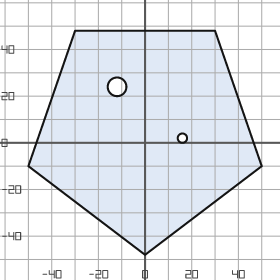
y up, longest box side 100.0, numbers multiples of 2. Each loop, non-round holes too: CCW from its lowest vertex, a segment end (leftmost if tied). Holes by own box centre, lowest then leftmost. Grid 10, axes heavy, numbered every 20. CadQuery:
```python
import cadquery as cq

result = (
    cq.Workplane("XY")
    .moveTo(0.0, -48.0)
    .lineTo(50.0, -10.0)
    .lineTo(30.0, 48.0)
    .lineTo(-30.0, 48.0)
    .lineTo(-50.0, -10.0)
    .close()
    .moveTo(16.0, 2.0)
    .circle(2.0)
    .moveTo(-12.0, 24.0)
    .circle(4.0)
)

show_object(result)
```